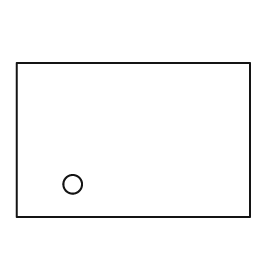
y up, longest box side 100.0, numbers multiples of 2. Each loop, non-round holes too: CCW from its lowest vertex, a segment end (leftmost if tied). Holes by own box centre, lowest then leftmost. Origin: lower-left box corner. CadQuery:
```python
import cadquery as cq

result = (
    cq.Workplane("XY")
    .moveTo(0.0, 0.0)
    .lineTo(100.0, 0.0)
    .lineTo(100.0, 66.0)
    .lineTo(0.0, 66.0)
    .close()
    .moveTo(24.0, 14.0)
    .circle(4.0)
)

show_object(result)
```